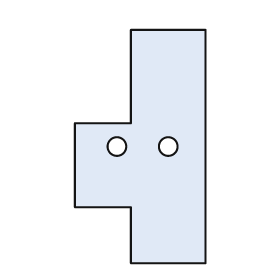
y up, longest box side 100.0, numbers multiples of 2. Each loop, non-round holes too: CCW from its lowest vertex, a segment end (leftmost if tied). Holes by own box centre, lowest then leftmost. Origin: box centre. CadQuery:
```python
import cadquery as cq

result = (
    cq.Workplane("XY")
    .moveTo(-4.0, -50.0)
    .lineTo(28.0, -50.0)
    .lineTo(28.0, 50.0)
    .lineTo(-4.0, 50.0)
    .lineTo(-4.0, 10.0)
    .lineTo(-28.0, 10.0)
    .lineTo(-28.0, -26.0)
    .lineTo(-4.0, -26.0)
    .close()
    .moveTo(-10.0, 0.0)
    .circle(4.0)
    .moveTo(12.0, 0.0)
    .circle(4.0)
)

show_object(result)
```